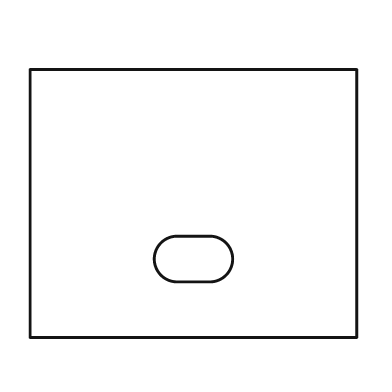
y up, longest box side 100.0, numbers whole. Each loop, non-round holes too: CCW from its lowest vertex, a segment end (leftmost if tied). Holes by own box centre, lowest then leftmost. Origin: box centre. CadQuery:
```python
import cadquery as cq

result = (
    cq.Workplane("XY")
    .moveTo(-50.0, -41.0)
    .lineTo(50.0, -41.0)
    .lineTo(50.0, 41.0)
    .lineTo(-50.0, 41.0)
    .close()
    .moveTo(-5.0, -24.0)
    .lineTo(5.0, -24.0)
    .threePointArc((12.0, -17.0), (5.0, -10.0))
    .lineTo(-5.0, -10.0)
    .threePointArc((-12.0, -17.0), (-5.0, -24.0))
    .close()
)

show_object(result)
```